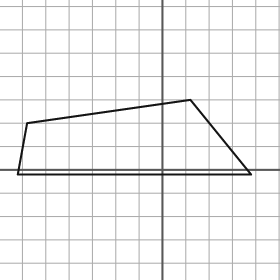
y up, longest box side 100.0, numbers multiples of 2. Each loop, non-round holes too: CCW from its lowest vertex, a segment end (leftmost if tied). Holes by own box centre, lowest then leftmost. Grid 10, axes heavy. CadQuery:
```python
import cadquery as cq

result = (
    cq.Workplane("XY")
    .moveTo(-62.0, -2.0)
    .lineTo(38.0, -2.0)
    .lineTo(12.0, 30.0)
    .lineTo(-58.0, 20.0)
    .close()
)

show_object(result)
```